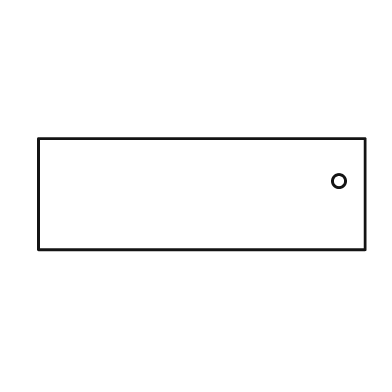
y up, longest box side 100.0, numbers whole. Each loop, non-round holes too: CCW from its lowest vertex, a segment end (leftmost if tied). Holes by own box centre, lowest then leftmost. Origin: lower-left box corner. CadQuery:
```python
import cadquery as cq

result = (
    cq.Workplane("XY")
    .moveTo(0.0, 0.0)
    .lineTo(100.0, 0.0)
    .lineTo(100.0, 34.0)
    .lineTo(0.0, 34.0)
    .close()
    .moveTo(92.0, 21.0)
    .circle(2.0)
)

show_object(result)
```